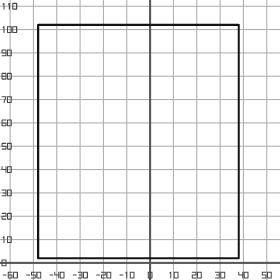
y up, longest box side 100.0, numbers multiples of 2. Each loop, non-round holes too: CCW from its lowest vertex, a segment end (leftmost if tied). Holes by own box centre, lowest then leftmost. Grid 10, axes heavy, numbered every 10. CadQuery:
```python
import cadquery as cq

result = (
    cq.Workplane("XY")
    .moveTo(-48.0, 2.0)
    .lineTo(38.0, 2.0)
    .lineTo(38.0, 102.0)
    .lineTo(-48.0, 102.0)
    .close()
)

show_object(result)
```